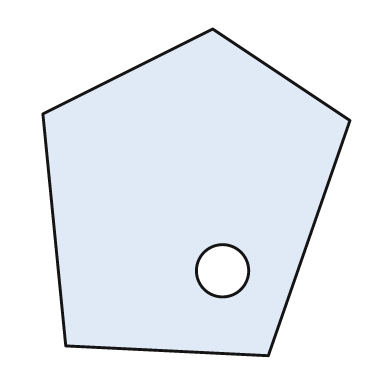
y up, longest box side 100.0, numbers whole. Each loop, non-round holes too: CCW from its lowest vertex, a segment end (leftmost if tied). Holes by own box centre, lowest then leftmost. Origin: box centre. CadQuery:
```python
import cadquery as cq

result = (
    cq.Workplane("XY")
    .moveTo(22.0, -50.0)
    .lineTo(47.0, 22.0)
    .lineTo(5.0, 50.0)
    .lineTo(-47.0, 24.0)
    .lineTo(-40.0, -47.0)
    .close()
    .moveTo(8.0, -24.0)
    .circle(8.0)
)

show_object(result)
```